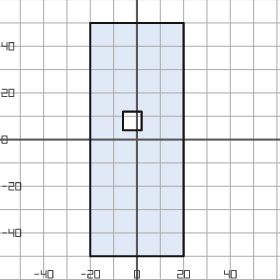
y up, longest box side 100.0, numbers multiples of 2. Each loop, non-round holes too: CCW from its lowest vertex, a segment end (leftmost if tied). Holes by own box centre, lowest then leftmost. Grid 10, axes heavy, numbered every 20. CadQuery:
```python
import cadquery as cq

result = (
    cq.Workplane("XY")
    .moveTo(-20.0, -50.0)
    .lineTo(20.0, -50.0)
    .lineTo(20.0, 50.0)
    .lineTo(-20.0, 50.0)
    .close()
    .moveTo(-6.0, 4.0)
    .lineTo(2.0, 4.0)
    .lineTo(2.0, 12.0)
    .lineTo(-6.0, 12.0)
    .close()
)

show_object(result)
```